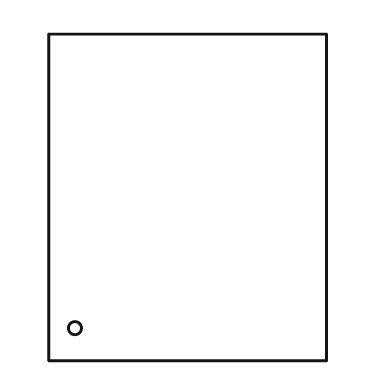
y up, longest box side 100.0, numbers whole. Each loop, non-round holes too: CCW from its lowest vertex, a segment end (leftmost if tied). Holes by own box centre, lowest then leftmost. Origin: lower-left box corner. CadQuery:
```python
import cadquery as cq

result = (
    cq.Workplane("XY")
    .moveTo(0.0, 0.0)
    .lineTo(85.0, 0.0)
    .lineTo(85.0, 100.0)
    .lineTo(0.0, 100.0)
    .close()
    .moveTo(8.0, 10.0)
    .circle(2.0)
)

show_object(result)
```